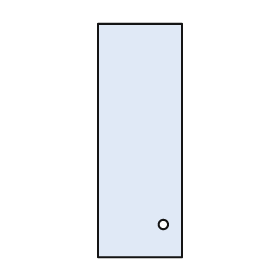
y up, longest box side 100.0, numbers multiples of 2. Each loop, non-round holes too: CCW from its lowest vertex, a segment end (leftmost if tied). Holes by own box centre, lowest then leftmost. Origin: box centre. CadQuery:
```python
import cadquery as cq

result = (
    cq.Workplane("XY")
    .moveTo(-18.0, -50.0)
    .lineTo(18.0, -50.0)
    .lineTo(18.0, 50.0)
    .lineTo(-18.0, 50.0)
    .close()
    .moveTo(10.0, -36.0)
    .circle(2.0)
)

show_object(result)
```